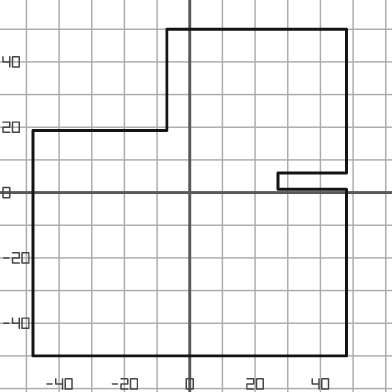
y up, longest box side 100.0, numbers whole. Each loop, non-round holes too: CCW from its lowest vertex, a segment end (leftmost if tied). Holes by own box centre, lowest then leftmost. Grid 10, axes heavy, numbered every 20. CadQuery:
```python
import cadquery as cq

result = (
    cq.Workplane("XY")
    .moveTo(-48.0, -50.0)
    .lineTo(48.0, -50.0)
    .lineTo(48.0, 1.0)
    .lineTo(27.0, 1.0)
    .lineTo(27.0, 6.0)
    .lineTo(48.0, 6.0)
    .lineTo(48.0, 50.0)
    .lineTo(-7.0, 50.0)
    .lineTo(-7.0, 19.0)
    .lineTo(-48.0, 19.0)
    .close()
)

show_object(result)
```